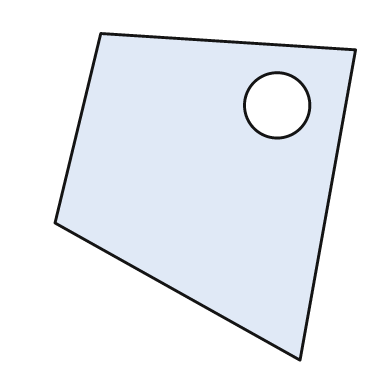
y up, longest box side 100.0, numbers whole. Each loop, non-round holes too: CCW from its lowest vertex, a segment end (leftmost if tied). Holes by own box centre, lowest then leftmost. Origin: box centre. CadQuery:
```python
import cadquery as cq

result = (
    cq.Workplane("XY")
    .moveTo(29.0, -50.0)
    .lineTo(46.0, 45.0)
    .lineTo(-32.0, 50.0)
    .lineTo(-46.0, -8.0)
    .close()
    .moveTo(22.0, 28.0)
    .circle(10.0)
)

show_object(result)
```